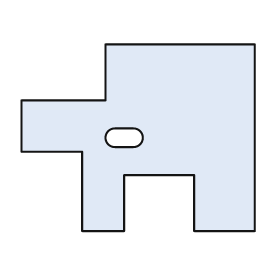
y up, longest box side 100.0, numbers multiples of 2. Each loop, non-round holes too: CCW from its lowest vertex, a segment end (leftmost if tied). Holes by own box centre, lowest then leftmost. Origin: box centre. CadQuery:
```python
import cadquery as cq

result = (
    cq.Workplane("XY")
    .moveTo(-24.0, -40.0)
    .lineTo(-6.0, -40.0)
    .lineTo(-6.0, -16.0)
    .lineTo(24.0, -16.0)
    .lineTo(24.0, -40.0)
    .lineTo(50.0, -40.0)
    .lineTo(50.0, 40.0)
    .lineTo(-14.0, 40.0)
    .lineTo(-14.0, 16.0)
    .lineTo(-50.0, 16.0)
    .lineTo(-50.0, -6.0)
    .lineTo(-24.0, -6.0)
    .close()
    .moveTo(-10.0, -4.0)
    .lineTo(-2.0, -4.0)
    .threePointArc((2.0, 0.0), (-2.0, 4.0))
    .lineTo(-10.0, 4.0)
    .threePointArc((-14.0, 0.0), (-10.0, -4.0))
    .close()
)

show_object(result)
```